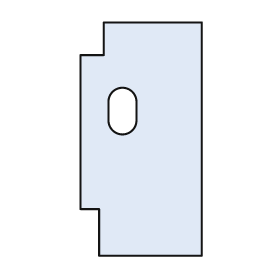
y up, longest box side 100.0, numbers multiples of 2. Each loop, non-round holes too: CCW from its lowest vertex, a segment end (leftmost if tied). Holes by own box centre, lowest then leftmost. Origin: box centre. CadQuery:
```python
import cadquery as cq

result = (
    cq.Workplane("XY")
    .moveTo(-18.0, -50.0)
    .lineTo(26.0, -50.0)
    .lineTo(26.0, 50.0)
    .lineTo(-16.0, 50.0)
    .lineTo(-16.0, 36.0)
    .lineTo(-26.0, 36.0)
    .lineTo(-26.0, -30.0)
    .lineTo(-18.0, -30.0)
    .close()
    .moveTo(-14.0, 8.0)
    .threePointArc((-8.0, 2.0), (-2.0, 8.0))
    .lineTo(-2.0, 16.0)
    .threePointArc((-8.0, 22.0), (-14.0, 16.0))
    .close()
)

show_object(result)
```